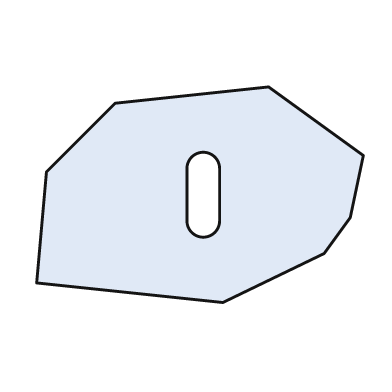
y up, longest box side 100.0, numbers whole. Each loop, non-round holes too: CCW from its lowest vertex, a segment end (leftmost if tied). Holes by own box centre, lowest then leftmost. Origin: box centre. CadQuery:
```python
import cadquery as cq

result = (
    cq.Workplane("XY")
    .moveTo(7.0, -33.0)
    .lineTo(38.0, -18.0)
    .lineTo(46.0, -7.0)
    .lineTo(50.0, 12.0)
    .lineTo(21.0, 33.0)
    .lineTo(-26.0, 28.0)
    .lineTo(-47.0, 7.0)
    .lineTo(-50.0, -27.0)
    .close()
    .moveTo(-4.0, -8.0)
    .threePointArc((1.0, -13.0), (6.0, -8.0))
    .lineTo(6.0, 8.0)
    .threePointArc((1.0, 13.0), (-4.0, 8.0))
    .close()
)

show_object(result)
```